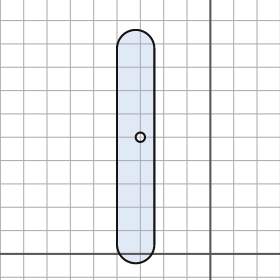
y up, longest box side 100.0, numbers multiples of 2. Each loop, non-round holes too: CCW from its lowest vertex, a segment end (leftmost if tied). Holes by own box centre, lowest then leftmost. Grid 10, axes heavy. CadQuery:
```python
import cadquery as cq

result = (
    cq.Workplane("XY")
    .moveTo(-40.0, 4.0)
    .threePointArc((-32.0, -4.0), (-24.0, 4.0))
    .lineTo(-24.0, 88.0)
    .threePointArc((-32.0, 96.0), (-40.0, 88.0))
    .close()
    .moveTo(-30.0, 50.0)
    .circle(2.0)
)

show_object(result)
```